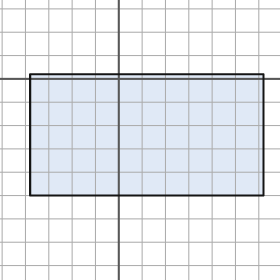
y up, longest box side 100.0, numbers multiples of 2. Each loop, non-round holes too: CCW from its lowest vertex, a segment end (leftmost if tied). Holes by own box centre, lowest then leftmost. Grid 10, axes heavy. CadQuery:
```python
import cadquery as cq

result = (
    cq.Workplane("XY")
    .moveTo(-38.0, -50.0)
    .lineTo(62.0, -50.0)
    .lineTo(62.0, 2.0)
    .lineTo(-38.0, 2.0)
    .close()
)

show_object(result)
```